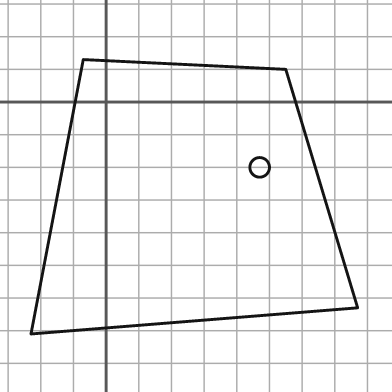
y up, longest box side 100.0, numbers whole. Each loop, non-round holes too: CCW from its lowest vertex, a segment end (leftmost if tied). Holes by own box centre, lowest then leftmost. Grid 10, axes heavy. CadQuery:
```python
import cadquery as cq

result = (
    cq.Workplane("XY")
    .moveTo(-23.0, -71.0)
    .lineTo(77.0, -63.0)
    .lineTo(55.0, 10.0)
    .lineTo(-7.0, 13.0)
    .close()
    .moveTo(47.0, -20.0)
    .circle(3.0)
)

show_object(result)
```